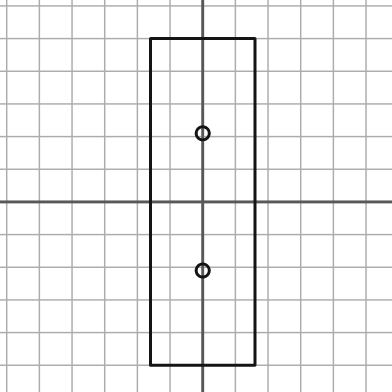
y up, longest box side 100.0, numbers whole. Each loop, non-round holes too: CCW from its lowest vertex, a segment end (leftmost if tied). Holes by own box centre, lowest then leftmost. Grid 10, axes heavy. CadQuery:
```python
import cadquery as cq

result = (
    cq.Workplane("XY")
    .moveTo(-16.0, -50.0)
    .lineTo(16.0, -50.0)
    .lineTo(16.0, 50.0)
    .lineTo(-16.0, 50.0)
    .close()
    .moveTo(0.0, -21.0)
    .circle(2.0)
    .moveTo(0.0, 21.0)
    .circle(2.0)
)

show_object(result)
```